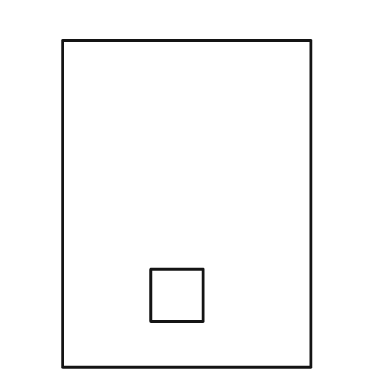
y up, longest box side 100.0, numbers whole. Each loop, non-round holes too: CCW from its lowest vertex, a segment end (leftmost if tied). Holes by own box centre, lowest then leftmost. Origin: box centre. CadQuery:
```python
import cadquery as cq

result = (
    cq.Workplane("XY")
    .moveTo(-38.0, -50.0)
    .lineTo(38.0, -50.0)
    .lineTo(38.0, 50.0)
    .lineTo(-38.0, 50.0)
    .close()
    .moveTo(-11.0, -36.0)
    .lineTo(5.0, -36.0)
    .lineTo(5.0, -20.0)
    .lineTo(-11.0, -20.0)
    .close()
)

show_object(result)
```